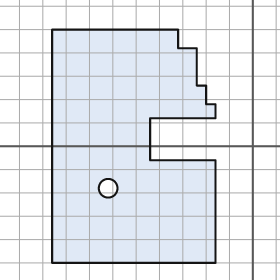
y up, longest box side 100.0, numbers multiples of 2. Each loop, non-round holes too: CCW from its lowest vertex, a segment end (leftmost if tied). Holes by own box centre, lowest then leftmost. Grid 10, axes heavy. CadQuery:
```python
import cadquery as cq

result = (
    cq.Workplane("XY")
    .moveTo(-86.0, -50.0)
    .lineTo(-16.0, -50.0)
    .lineTo(-16.0, -6.0)
    .lineTo(-44.0, -6.0)
    .lineTo(-44.0, 12.0)
    .lineTo(-16.0, 12.0)
    .lineTo(-16.0, 18.0)
    .lineTo(-20.0, 18.0)
    .lineTo(-20.0, 26.0)
    .lineTo(-24.0, 26.0)
    .lineTo(-24.0, 42.0)
    .lineTo(-32.0, 42.0)
    .lineTo(-32.0, 50.0)
    .lineTo(-86.0, 50.0)
    .close()
    .moveTo(-62.0, -18.0)
    .circle(4.0)
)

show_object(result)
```